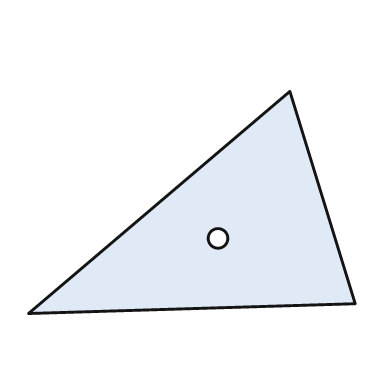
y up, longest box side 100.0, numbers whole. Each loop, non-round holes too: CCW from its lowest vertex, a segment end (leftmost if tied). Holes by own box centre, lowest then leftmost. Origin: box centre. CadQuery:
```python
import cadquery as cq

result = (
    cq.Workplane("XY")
    .moveTo(-50.0, -34.0)
    .lineTo(50.0, -31.0)
    .lineTo(30.0, 34.0)
    .close()
    .moveTo(8.0, -11.0)
    .circle(3.0)
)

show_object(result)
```